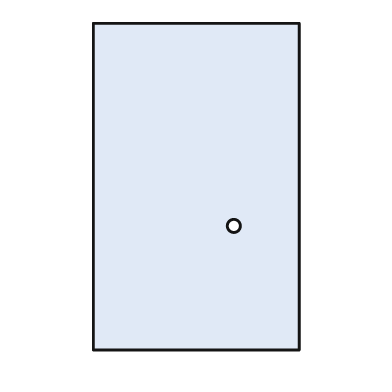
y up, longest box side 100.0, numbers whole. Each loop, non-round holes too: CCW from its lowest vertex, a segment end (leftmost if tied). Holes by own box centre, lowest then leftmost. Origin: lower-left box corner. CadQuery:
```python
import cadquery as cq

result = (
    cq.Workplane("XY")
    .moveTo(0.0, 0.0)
    .lineTo(63.0, 0.0)
    .lineTo(63.0, 100.0)
    .lineTo(0.0, 100.0)
    .close()
    .moveTo(43.0, 38.0)
    .circle(2.0)
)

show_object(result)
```